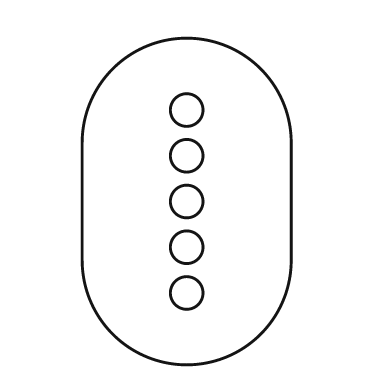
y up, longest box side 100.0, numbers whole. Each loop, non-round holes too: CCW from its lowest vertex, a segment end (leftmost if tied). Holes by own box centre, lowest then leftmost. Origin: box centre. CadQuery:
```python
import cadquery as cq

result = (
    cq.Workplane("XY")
    .moveTo(-32.0, -18.0)
    .threePointArc((0.0, -50.0), (32.0, -18.0))
    .lineTo(32.0, 18.0)
    .threePointArc((0.0, 50.0), (-32.0, 18.0))
    .close()
    .moveTo(0.0, -28.0)
    .circle(5.0)
    .moveTo(0.0, -14.0)
    .circle(5.0)
    .moveTo(0.0, 0.0)
    .circle(5.0)
    .moveTo(0.0, 14.0)
    .circle(5.0)
    .moveTo(0.0, 28.0)
    .circle(5.0)
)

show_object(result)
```